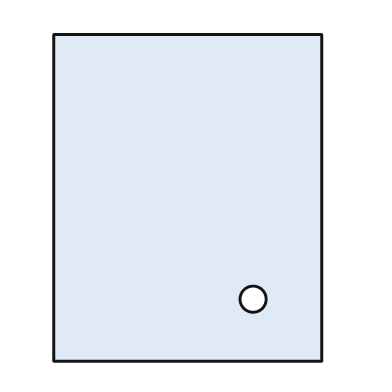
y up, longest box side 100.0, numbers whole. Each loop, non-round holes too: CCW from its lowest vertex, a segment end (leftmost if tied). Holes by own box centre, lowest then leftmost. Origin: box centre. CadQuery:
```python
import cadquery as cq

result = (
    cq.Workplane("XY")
    .moveTo(-41.0, -50.0)
    .lineTo(41.0, -50.0)
    .lineTo(41.0, 50.0)
    .lineTo(-41.0, 50.0)
    .close()
    .moveTo(20.0, -31.0)
    .circle(4.0)
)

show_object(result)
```